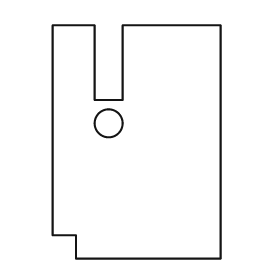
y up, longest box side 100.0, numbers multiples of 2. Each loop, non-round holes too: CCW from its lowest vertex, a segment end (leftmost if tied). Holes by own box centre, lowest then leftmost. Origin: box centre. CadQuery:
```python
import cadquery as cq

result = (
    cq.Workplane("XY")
    .moveTo(-26.0, -50.0)
    .lineTo(36.0, -50.0)
    .lineTo(36.0, 50.0)
    .lineTo(-6.0, 50.0)
    .lineTo(-6.0, 18.0)
    .lineTo(-18.0, 18.0)
    .lineTo(-18.0, 50.0)
    .lineTo(-36.0, 50.0)
    .lineTo(-36.0, -40.0)
    .lineTo(-26.0, -40.0)
    .close()
    .moveTo(-12.0, 8.0)
    .circle(6.0)
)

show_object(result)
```